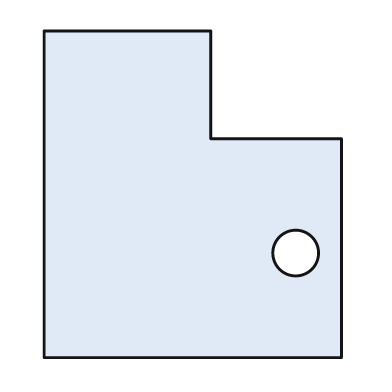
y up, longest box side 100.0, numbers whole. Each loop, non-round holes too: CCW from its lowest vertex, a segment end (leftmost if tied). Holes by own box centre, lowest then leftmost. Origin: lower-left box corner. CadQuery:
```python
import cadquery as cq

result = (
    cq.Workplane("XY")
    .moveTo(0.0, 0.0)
    .lineTo(91.0, 0.0)
    .lineTo(91.0, 67.0)
    .lineTo(51.0, 67.0)
    .lineTo(51.0, 100.0)
    .lineTo(0.0, 100.0)
    .close()
    .moveTo(77.0, 32.0)
    .circle(7.0)
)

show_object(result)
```